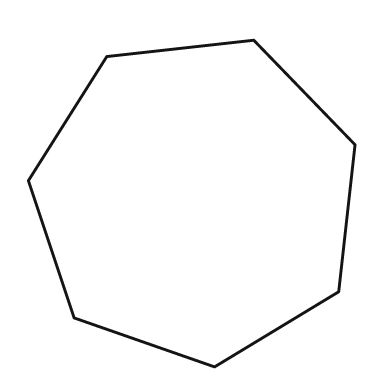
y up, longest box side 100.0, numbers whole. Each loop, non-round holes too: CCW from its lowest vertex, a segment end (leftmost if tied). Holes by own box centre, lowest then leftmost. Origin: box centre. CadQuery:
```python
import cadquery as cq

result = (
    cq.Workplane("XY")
    .moveTo(7.0, -50.0)
    .lineTo(45.0, -27.0)
    .lineTo(50.0, 18.0)
    .lineTo(19.0, 50.0)
    .lineTo(-26.0, 45.0)
    .lineTo(-50.0, 7.0)
    .lineTo(-36.0, -35.0)
    .close()
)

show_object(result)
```